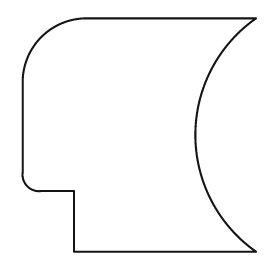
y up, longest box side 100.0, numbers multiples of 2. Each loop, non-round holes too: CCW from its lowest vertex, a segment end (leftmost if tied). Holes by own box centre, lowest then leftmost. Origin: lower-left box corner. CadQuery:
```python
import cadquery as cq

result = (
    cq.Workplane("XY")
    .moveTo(22.0, 0.0)
    .lineTo(100.0, 0.0)
    .threePointArc((74.0, 50.0), (100.0, 100.0))
    .lineTo(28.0, 100.0)
    .threePointArc((8.0, 92.0), (0.0, 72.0))
    .lineTo(0.0, 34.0)
    .threePointArc((2.0, 28.0), (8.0, 26.0))
    .lineTo(22.0, 26.0)
    .close()
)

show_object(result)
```